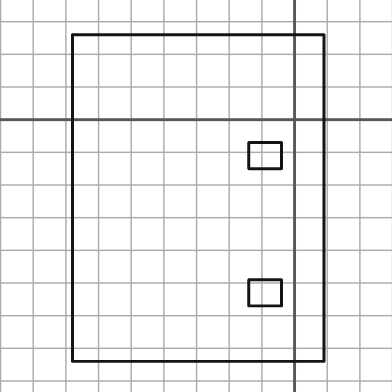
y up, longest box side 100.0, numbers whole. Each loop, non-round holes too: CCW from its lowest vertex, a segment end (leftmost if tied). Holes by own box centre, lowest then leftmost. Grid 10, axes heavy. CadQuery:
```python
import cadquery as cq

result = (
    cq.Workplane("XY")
    .moveTo(-68.0, -74.0)
    .lineTo(9.0, -74.0)
    .lineTo(9.0, 26.0)
    .lineTo(-68.0, 26.0)
    .close()
    .moveTo(-14.0, -57.0)
    .lineTo(-4.0, -57.0)
    .lineTo(-4.0, -49.0)
    .lineTo(-14.0, -49.0)
    .close()
    .moveTo(-14.0, -15.0)
    .lineTo(-4.0, -15.0)
    .lineTo(-4.0, -7.0)
    .lineTo(-14.0, -7.0)
    .close()
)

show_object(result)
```